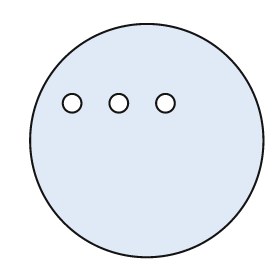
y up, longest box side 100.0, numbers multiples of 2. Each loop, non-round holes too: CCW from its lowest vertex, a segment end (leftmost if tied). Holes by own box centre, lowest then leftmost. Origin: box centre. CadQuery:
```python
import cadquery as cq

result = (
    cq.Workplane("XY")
    .moveTo(0.0, 0.0)
    .circle(50.0)
    .moveTo(-32.0, 16.0)
    .circle(4.0)
    .moveTo(-12.0, 16.0)
    .circle(4.0)
    .moveTo(8.0, 16.0)
    .circle(4.0)
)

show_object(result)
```